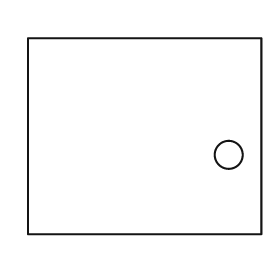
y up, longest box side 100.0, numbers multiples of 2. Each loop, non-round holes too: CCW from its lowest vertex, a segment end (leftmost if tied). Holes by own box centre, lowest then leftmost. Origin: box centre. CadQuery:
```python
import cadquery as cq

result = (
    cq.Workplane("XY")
    .moveTo(-50.0, -42.0)
    .lineTo(50.0, -42.0)
    .lineTo(50.0, 42.0)
    .lineTo(-50.0, 42.0)
    .close()
    .moveTo(36.0, -8.0)
    .circle(6.0)
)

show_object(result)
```